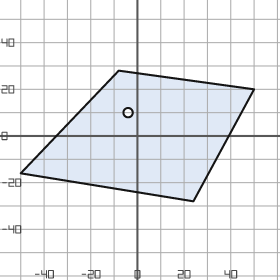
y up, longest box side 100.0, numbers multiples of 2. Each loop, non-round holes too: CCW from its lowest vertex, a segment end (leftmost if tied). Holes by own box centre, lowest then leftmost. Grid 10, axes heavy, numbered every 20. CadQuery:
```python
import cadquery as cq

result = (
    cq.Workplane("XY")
    .moveTo(24.0, -28.0)
    .lineTo(50.0, 20.0)
    .lineTo(-8.0, 28.0)
    .lineTo(-50.0, -16.0)
    .close()
    .moveTo(-4.0, 10.0)
    .circle(2.0)
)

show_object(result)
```